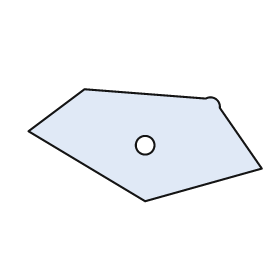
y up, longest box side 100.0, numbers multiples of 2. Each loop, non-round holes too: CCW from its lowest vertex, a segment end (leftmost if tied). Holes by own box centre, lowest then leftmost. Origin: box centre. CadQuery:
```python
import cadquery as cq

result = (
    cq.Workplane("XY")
    .moveTo(0.0, -24.0)
    .lineTo(50.0, -10.0)
    .lineTo(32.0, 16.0)
    .threePointArc((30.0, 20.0), (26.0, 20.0))
    .lineTo(-26.0, 24.0)
    .lineTo(-50.0, 6.0)
    .close()
    .moveTo(0.0, 0.0)
    .circle(4.0)
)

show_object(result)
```